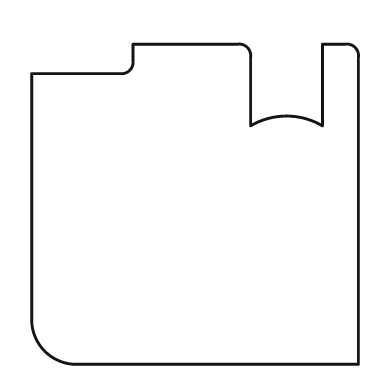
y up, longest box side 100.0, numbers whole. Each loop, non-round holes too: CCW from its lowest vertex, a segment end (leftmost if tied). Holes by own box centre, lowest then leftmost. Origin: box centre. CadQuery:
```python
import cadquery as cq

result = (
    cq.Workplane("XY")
    .moveTo(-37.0, -49.0)
    .lineTo(50.0, -49.0)
    .lineTo(50.0, 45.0)
    .threePointArc((49.0, 48.0), (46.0, 49.0))
    .lineTo(39.0, 49.0)
    .lineTo(39.0, 24.0)
    .threePointArc((28.0, 27.0), (17.0, 24.0))
    .lineTo(17.0, 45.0)
    .threePointArc((16.0, 48.0), (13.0, 49.0))
    .lineTo(-19.0, 49.0)
    .lineTo(-19.0, 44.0)
    .threePointArc((-20.0, 41.0), (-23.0, 40.0))
    .lineTo(-50.0, 40.0)
    .lineTo(-50.0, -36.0)
    .threePointArc((-46.0, -45.0), (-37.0, -49.0))
    .close()
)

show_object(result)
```